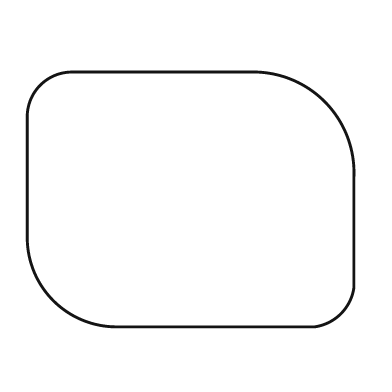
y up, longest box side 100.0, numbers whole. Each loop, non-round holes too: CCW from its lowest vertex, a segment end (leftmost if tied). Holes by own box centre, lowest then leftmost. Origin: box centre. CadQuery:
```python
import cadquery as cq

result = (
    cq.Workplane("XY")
    .moveTo(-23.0, -39.0)
    .lineTo(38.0, -39.0)
    .threePointArc((46.0, -35.0), (50.0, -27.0))
    .lineTo(50.0, 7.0)
    .threePointArc((41.0, 30.0), (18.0, 39.0))
    .lineTo(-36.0, 39.0)
    .threePointArc((-46.0, 35.0), (-50.0, 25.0))
    .lineTo(-50.0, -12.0)
    .threePointArc((-42.0, -31.0), (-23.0, -39.0))
    .close()
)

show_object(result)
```